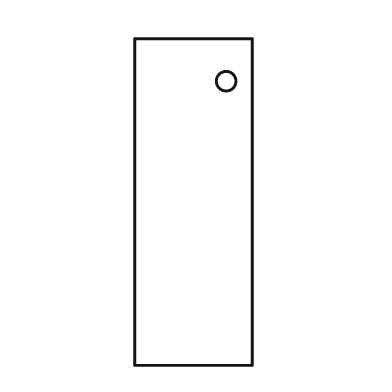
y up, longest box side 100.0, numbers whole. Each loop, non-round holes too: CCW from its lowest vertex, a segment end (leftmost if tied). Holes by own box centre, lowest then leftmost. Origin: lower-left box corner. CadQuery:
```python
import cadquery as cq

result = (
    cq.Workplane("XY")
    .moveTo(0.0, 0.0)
    .lineTo(36.0, 0.0)
    .lineTo(36.0, 100.0)
    .lineTo(0.0, 100.0)
    .close()
    .moveTo(28.0, 87.0)
    .circle(3.0)
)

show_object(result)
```